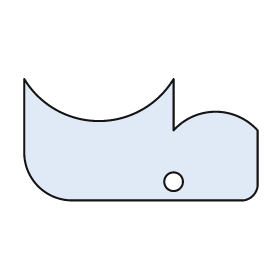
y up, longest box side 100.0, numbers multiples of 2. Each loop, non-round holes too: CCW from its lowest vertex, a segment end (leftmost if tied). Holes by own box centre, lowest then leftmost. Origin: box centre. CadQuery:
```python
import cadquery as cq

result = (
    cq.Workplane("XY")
    .moveTo(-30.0, -26.0)
    .lineTo(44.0, -26.0)
    .threePointArc((48.0, -24.0), (50.0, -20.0))
    .lineTo(50.0, 4.0)
    .threePointArc((32.0, 12.0), (14.0, 4.0))
    .lineTo(14.0, 26.0)
    .threePointArc((-18.0, 8.0), (-50.0, 26.0))
    .lineTo(-50.0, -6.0)
    .threePointArc((-44.0, -20.0), (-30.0, -26.0))
    .close()
    .moveTo(14.0, -18.0)
    .circle(4.0)
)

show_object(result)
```